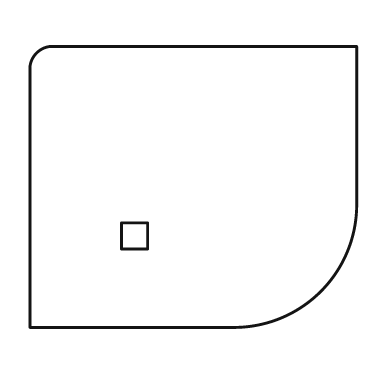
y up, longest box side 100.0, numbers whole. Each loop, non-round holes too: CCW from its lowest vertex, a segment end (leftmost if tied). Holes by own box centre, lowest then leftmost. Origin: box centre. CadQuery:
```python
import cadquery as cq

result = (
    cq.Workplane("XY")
    .moveTo(-50.0, -43.0)
    .lineTo(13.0, -43.0)
    .threePointArc((39.0, -32.0), (50.0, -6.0))
    .lineTo(50.0, 43.0)
    .lineTo(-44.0, 43.0)
    .threePointArc((-48.0, 41.0), (-50.0, 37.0))
    .close()
    .moveTo(-22.0, -19.0)
    .lineTo(-14.0, -19.0)
    .lineTo(-14.0, -11.0)
    .lineTo(-22.0, -11.0)
    .close()
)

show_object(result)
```